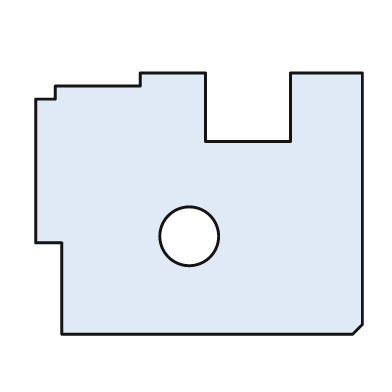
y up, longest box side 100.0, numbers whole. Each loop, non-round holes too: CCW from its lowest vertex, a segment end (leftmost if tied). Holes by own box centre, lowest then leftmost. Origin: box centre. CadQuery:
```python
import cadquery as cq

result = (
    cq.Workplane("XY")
    .moveTo(-42.0, -40.0)
    .lineTo(47.0, -40.0)
    .lineTo(50.0, -37.0)
    .lineTo(50.0, 40.0)
    .lineTo(28.0, 40.0)
    .lineTo(28.0, 19.0)
    .lineTo(2.0, 19.0)
    .lineTo(2.0, 40.0)
    .lineTo(-18.0, 40.0)
    .lineTo(-18.0, 36.0)
    .lineTo(-44.0, 36.0)
    .lineTo(-44.0, 32.0)
    .lineTo(-50.0, 32.0)
    .lineTo(-50.0, -12.0)
    .lineTo(-42.0, -12.0)
    .close()
    .moveTo(-3.0, -10.0)
    .circle(9.0)
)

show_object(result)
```